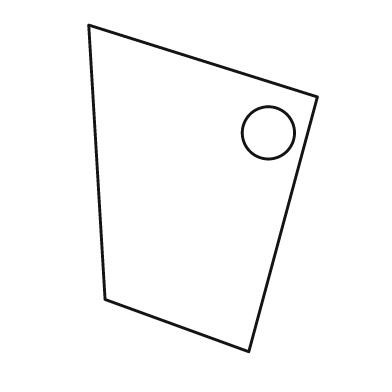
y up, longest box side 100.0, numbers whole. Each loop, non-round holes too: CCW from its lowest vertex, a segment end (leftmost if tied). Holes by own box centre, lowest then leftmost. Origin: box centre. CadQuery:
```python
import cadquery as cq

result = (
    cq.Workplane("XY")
    .moveTo(14.0, -50.0)
    .lineTo(35.0, 28.0)
    .lineTo(-35.0, 50.0)
    .lineTo(-30.0, -34.0)
    .close()
    .moveTo(20.0, 17.0)
    .circle(8.0)
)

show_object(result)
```